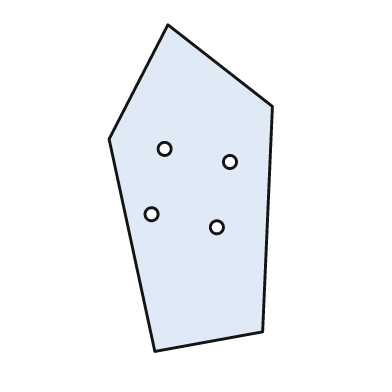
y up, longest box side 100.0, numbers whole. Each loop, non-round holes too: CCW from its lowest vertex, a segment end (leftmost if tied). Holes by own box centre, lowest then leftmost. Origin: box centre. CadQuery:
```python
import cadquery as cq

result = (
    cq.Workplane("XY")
    .moveTo(-11.0, -50.0)
    .lineTo(22.0, -44.0)
    .lineTo(25.0, 25.0)
    .lineTo(-7.0, 50.0)
    .lineTo(-25.0, 15.0)
    .close()
    .moveTo(8.0, -12.0)
    .circle(2.0)
    .moveTo(-12.0, -8.0)
    .circle(2.0)
    .moveTo(12.0, 8.0)
    .circle(2.0)
    .moveTo(-8.0, 12.0)
    .circle(2.0)
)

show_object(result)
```